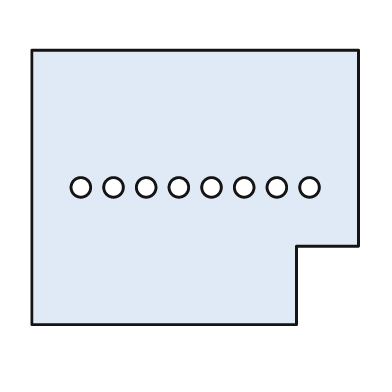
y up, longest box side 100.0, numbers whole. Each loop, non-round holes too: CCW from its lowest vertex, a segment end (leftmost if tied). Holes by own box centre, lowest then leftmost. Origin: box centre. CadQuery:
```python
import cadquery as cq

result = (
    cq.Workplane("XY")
    .moveTo(-50.0, -42.0)
    .lineTo(31.0, -42.0)
    .lineTo(31.0, -18.0)
    .lineTo(50.0, -18.0)
    .lineTo(50.0, 42.0)
    .lineTo(-50.0, 42.0)
    .close()
    .moveTo(-35.0, 0.0)
    .circle(3.0)
    .moveTo(-25.0, 0.0)
    .circle(3.0)
    .moveTo(-15.0, 0.0)
    .circle(3.0)
    .moveTo(-5.0, 0.0)
    .circle(3.0)
    .moveTo(5.0, 0.0)
    .circle(3.0)
    .moveTo(15.0, 0.0)
    .circle(3.0)
    .moveTo(25.0, 0.0)
    .circle(3.0)
    .moveTo(35.0, 0.0)
    .circle(3.0)
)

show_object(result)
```